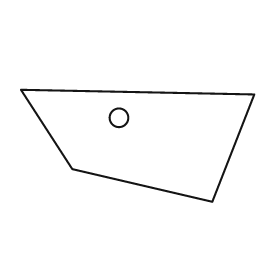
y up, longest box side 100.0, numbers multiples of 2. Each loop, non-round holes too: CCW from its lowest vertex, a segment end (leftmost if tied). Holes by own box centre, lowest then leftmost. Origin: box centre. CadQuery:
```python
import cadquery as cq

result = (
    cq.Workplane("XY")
    .moveTo(32.0, -24.0)
    .lineTo(50.0, 22.0)
    .lineTo(-50.0, 24.0)
    .lineTo(-28.0, -10.0)
    .close()
    .moveTo(-8.0, 12.0)
    .circle(4.0)
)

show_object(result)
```